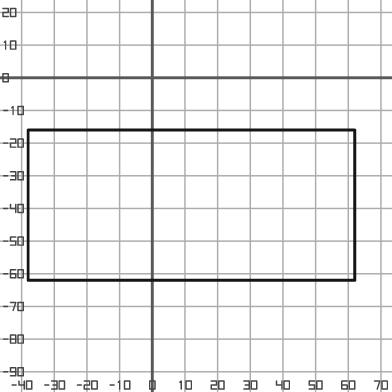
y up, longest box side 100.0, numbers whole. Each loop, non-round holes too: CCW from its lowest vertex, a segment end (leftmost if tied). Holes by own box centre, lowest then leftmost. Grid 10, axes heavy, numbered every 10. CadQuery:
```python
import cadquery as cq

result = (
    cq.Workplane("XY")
    .moveTo(-38.0, -62.0)
    .lineTo(62.0, -62.0)
    .lineTo(62.0, -16.0)
    .lineTo(-38.0, -16.0)
    .close()
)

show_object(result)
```